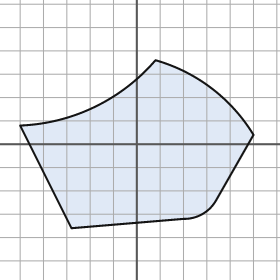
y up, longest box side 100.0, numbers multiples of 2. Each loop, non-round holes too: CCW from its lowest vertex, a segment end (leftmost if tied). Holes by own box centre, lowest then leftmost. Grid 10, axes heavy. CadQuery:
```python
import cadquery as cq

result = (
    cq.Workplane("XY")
    .moveTo(-28.0, -36.0)
    .lineTo(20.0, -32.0)
    .threePointArc((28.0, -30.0), (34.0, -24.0))
    .lineTo(50.0, 4.0)
    .threePointArc((32.0, 24.0), (8.0, 36.0))
    .threePointArc((-18.0, 16.0), (-50.0, 8.0))
    .close()
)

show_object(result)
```